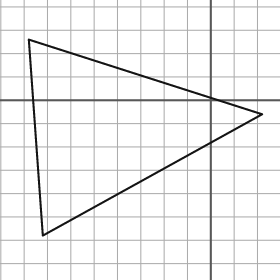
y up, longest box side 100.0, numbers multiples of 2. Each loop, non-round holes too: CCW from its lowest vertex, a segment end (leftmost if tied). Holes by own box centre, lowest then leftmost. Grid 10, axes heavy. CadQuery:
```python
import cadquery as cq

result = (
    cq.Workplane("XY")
    .moveTo(-72.0, -58.0)
    .lineTo(22.0, -6.0)
    .lineTo(-78.0, 26.0)
    .close()
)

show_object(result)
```